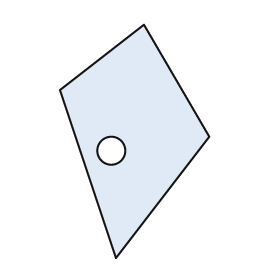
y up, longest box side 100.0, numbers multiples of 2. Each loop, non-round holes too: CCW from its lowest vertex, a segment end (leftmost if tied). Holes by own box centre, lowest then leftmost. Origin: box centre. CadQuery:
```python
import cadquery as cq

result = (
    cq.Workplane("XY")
    .moveTo(-8.0, -50.0)
    .lineTo(32.0, 2.0)
    .lineTo(4.0, 50.0)
    .lineTo(-32.0, 22.0)
    .close()
    .moveTo(-10.0, -4.0)
    .circle(6.0)
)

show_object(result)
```